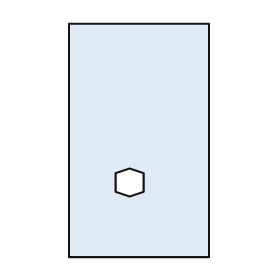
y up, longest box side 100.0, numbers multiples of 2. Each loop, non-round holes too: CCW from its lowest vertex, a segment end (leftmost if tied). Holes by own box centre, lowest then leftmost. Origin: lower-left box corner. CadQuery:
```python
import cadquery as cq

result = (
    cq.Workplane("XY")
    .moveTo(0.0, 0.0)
    .lineTo(60.0, 0.0)
    .lineTo(60.0, 100.0)
    .lineTo(0.0, 100.0)
    .close()
    .moveTo(26.0, 26.0)
    .lineTo(32.0, 28.0)
    .lineTo(32.0, 36.0)
    .lineTo(26.0, 38.0)
    .lineTo(20.0, 36.0)
    .lineTo(20.0, 28.0)
    .close()
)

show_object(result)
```